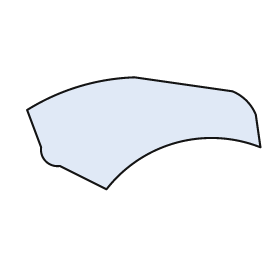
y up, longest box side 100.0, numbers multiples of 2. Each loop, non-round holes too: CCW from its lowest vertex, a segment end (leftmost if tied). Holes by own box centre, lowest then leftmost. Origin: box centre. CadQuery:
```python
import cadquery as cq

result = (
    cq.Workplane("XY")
    .moveTo(-16.0, -24.0)
    .threePointArc((14.0, -4.0), (50.0, -6.0))
    .lineTo(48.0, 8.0)
    .threePointArc((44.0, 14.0), (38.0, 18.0))
    .lineTo(-4.0, 24.0)
    .threePointArc((-28.0, 20.0), (-50.0, 10.0))
    .lineTo(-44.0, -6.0)
    .threePointArc((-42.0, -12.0), (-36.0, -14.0))
    .close()
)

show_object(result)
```